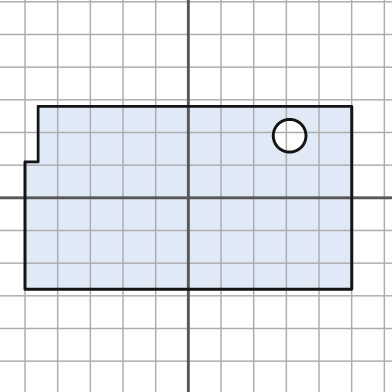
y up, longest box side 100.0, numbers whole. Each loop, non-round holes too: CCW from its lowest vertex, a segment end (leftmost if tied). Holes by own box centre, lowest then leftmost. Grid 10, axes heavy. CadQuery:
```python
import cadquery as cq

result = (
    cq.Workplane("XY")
    .moveTo(-50.0, -28.0)
    .lineTo(50.0, -28.0)
    .lineTo(50.0, 28.0)
    .lineTo(-46.0, 28.0)
    .lineTo(-46.0, 11.0)
    .lineTo(-50.0, 11.0)
    .close()
    .moveTo(31.0, 19.0)
    .circle(5.0)
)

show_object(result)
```